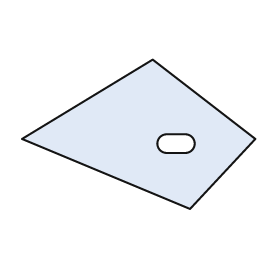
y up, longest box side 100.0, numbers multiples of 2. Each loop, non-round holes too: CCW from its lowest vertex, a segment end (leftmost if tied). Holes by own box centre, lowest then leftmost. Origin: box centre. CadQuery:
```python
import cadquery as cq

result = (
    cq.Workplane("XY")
    .moveTo(22.0, -32.0)
    .lineTo(50.0, -2.0)
    .lineTo(6.0, 32.0)
    .lineTo(-50.0, -2.0)
    .close()
    .moveTo(12.0, -8.0)
    .lineTo(20.0, -8.0)
    .threePointArc((24.0, -4.0), (20.0, 0.0))
    .lineTo(12.0, 0.0)
    .threePointArc((8.0, -4.0), (12.0, -8.0))
    .close()
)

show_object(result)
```